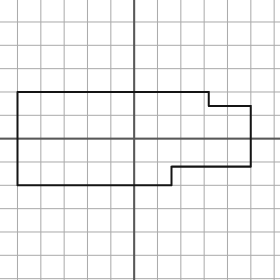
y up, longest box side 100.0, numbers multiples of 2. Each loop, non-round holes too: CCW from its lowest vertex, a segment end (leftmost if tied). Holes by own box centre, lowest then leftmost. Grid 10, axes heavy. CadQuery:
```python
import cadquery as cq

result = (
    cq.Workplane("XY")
    .moveTo(-50.0, -20.0)
    .lineTo(16.0, -20.0)
    .lineTo(16.0, -12.0)
    .lineTo(50.0, -12.0)
    .lineTo(50.0, 14.0)
    .lineTo(32.0, 14.0)
    .lineTo(32.0, 20.0)
    .lineTo(-50.0, 20.0)
    .close()
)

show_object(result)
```